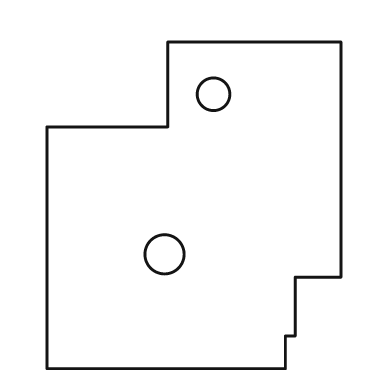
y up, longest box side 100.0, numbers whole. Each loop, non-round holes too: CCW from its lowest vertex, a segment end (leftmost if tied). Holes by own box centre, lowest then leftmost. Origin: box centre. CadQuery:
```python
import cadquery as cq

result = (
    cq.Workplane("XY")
    .moveTo(-45.0, -50.0)
    .lineTo(28.0, -50.0)
    .lineTo(28.0, -40.0)
    .lineTo(31.0, -40.0)
    .lineTo(31.0, -22.0)
    .lineTo(45.0, -22.0)
    .lineTo(45.0, 50.0)
    .lineTo(-8.0, 50.0)
    .lineTo(-8.0, 24.0)
    .lineTo(-45.0, 24.0)
    .close()
    .moveTo(-9.0, -15.0)
    .circle(6.0)
    .moveTo(6.0, 34.0)
    .circle(5.0)
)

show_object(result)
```